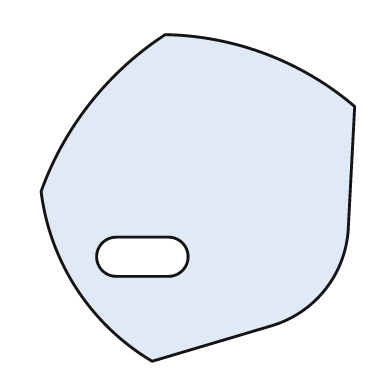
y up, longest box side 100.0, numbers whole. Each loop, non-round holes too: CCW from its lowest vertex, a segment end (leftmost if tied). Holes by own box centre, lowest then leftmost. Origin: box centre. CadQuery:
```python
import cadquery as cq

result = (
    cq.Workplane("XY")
    .moveTo(-14.0, -50.0)
    .lineTo(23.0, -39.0)
    .threePointArc((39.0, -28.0), (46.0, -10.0))
    .lineTo(48.0, 28.0)
    .threePointArc((21.0, 44.0), (-10.0, 50.0))
    .threePointArc((-33.0, 29.0), (-48.0, 2.0))
    .threePointArc((-37.0, -28.0), (-14.0, -50.0))
    .close()
    .moveTo(-25.0, -24.0)
    .lineTo(-9.0, -24.0)
    .threePointArc((-3.0, -18.0), (-9.0, -12.0))
    .lineTo(-25.0, -12.0)
    .threePointArc((-31.0, -18.0), (-25.0, -24.0))
    .close()
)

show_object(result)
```